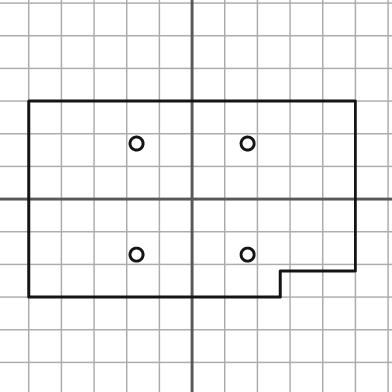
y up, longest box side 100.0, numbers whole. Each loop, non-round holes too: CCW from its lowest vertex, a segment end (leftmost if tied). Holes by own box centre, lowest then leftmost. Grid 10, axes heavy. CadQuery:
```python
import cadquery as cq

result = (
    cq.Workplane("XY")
    .moveTo(-50.0, -30.0)
    .lineTo(27.0, -30.0)
    .lineTo(27.0, -22.0)
    .lineTo(50.0, -22.0)
    .lineTo(50.0, 30.0)
    .lineTo(-50.0, 30.0)
    .close()
    .moveTo(-17.0, -17.0)
    .circle(2.0)
    .moveTo(17.0, -17.0)
    .circle(2.0)
    .moveTo(-17.0, 17.0)
    .circle(2.0)
    .moveTo(17.0, 17.0)
    .circle(2.0)
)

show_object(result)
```